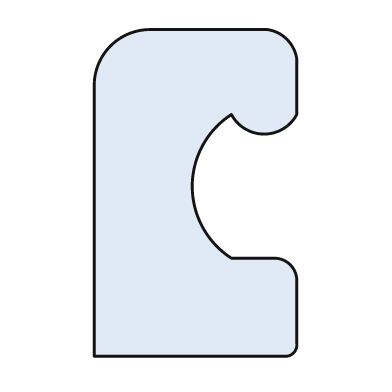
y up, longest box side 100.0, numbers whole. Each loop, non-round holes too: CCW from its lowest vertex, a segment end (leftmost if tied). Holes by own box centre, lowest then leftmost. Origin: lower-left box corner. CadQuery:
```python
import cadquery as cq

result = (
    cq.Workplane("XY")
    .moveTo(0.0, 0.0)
    .lineTo(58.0, 0.0)
    .threePointArc((61.0, 1.0), (62.0, 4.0))
    .lineTo(62.0, 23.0)
    .threePointArc((60.0, 28.0), (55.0, 30.0))
    .lineTo(42.0, 30.0)
    .threePointArc((30.0, 52.0), (42.0, 74.0))
    .threePointArc((52.0, 68.0), (62.0, 74.0))
    .lineTo(62.0, 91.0)
    .threePointArc((59.0, 97.0), (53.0, 100.0))
    .lineTo(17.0, 100.0)
    .threePointArc((5.0, 95.0), (0.0, 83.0))
    .close()
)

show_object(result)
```